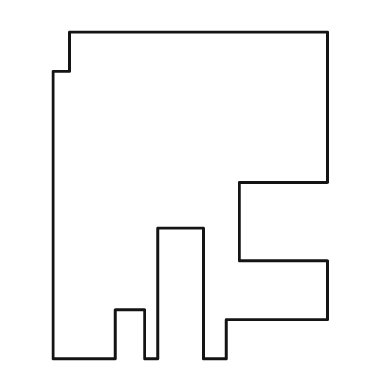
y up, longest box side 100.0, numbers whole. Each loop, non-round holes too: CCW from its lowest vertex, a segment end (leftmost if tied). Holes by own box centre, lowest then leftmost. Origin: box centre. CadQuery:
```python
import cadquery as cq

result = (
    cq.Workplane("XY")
    .moveTo(-42.0, -50.0)
    .lineTo(-23.0, -50.0)
    .lineTo(-23.0, -35.0)
    .lineTo(-14.0, -35.0)
    .lineTo(-14.0, -50.0)
    .lineTo(-10.0, -50.0)
    .lineTo(-10.0, -10.0)
    .lineTo(4.0, -10.0)
    .lineTo(4.0, -50.0)
    .lineTo(11.0, -50.0)
    .lineTo(11.0, -38.0)
    .lineTo(42.0, -38.0)
    .lineTo(42.0, -20.0)
    .lineTo(15.0, -20.0)
    .lineTo(15.0, 4.0)
    .lineTo(42.0, 4.0)
    .lineTo(42.0, 50.0)
    .lineTo(-37.0, 50.0)
    .lineTo(-37.0, 38.0)
    .lineTo(-42.0, 38.0)
    .close()
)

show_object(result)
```